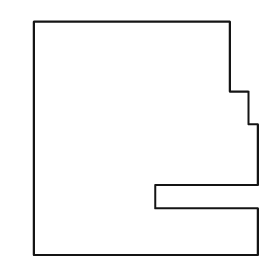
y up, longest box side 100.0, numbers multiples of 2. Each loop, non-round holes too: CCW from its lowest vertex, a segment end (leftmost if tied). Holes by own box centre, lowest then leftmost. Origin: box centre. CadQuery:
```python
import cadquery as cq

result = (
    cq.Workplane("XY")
    .moveTo(-48.0, -50.0)
    .lineTo(48.0, -50.0)
    .lineTo(48.0, -30.0)
    .lineTo(4.0, -30.0)
    .lineTo(4.0, -20.0)
    .lineTo(48.0, -20.0)
    .lineTo(48.0, 6.0)
    .lineTo(44.0, 6.0)
    .lineTo(44.0, 20.0)
    .lineTo(36.0, 20.0)
    .lineTo(36.0, 50.0)
    .lineTo(-48.0, 50.0)
    .close()
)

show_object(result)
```